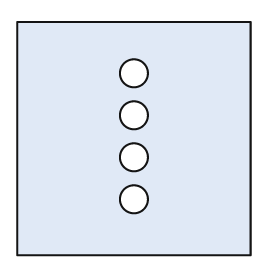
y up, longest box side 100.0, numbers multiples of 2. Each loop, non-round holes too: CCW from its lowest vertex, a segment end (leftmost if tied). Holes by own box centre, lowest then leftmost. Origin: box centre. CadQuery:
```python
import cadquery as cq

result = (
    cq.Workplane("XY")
    .moveTo(-50.0, -50.0)
    .lineTo(50.0, -50.0)
    .lineTo(50.0, 50.0)
    .lineTo(-50.0, 50.0)
    .close()
    .moveTo(0.0, -26.0)
    .circle(6.0)
    .moveTo(0.0, -8.0)
    .circle(6.0)
    .moveTo(0.0, 10.0)
    .circle(6.0)
    .moveTo(0.0, 28.0)
    .circle(6.0)
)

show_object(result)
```